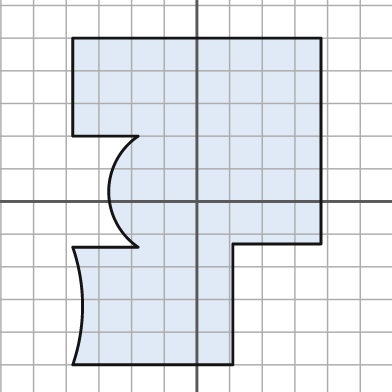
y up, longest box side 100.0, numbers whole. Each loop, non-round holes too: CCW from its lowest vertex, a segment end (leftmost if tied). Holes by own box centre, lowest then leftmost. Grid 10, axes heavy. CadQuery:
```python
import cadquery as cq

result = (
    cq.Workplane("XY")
    .moveTo(-38.0, -50.0)
    .lineTo(11.0, -50.0)
    .lineTo(11.0, -13.0)
    .lineTo(38.0, -13.0)
    .lineTo(38.0, 50.0)
    .lineTo(-38.0, 50.0)
    .lineTo(-38.0, 20.0)
    .lineTo(-18.0, 20.0)
    .threePointArc((-27.0, 3.0), (-18.0, -14.0))
    .lineTo(-38.0, -14.0)
    .threePointArc((-35.0, -32.0), (-38.0, -50.0))
    .close()
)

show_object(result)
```